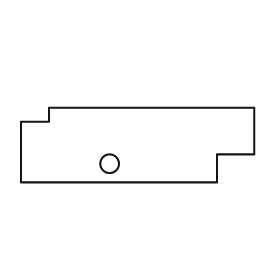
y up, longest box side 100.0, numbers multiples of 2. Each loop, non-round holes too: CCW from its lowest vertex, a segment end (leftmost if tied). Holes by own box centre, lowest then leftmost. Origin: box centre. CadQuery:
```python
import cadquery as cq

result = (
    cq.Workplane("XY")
    .moveTo(-50.0, -16.0)
    .lineTo(34.0, -16.0)
    .lineTo(34.0, -4.0)
    .lineTo(50.0, -4.0)
    .lineTo(50.0, 16.0)
    .lineTo(-38.0, 16.0)
    .lineTo(-38.0, 10.0)
    .lineTo(-50.0, 10.0)
    .close()
    .moveTo(-12.0, -8.0)
    .circle(4.0)
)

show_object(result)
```